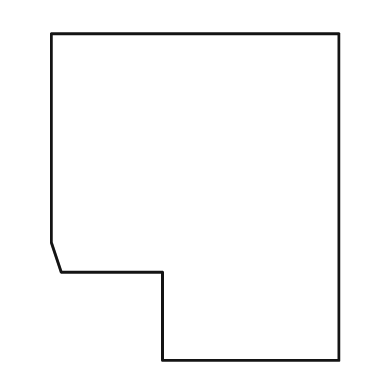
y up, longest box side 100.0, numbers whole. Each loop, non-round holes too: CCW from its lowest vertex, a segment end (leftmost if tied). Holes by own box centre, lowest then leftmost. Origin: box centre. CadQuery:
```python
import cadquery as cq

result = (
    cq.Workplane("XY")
    .moveTo(-10.0, -50.0)
    .lineTo(44.0, -50.0)
    .lineTo(44.0, 50.0)
    .lineTo(-44.0, 50.0)
    .lineTo(-44.0, -14.0)
    .lineTo(-41.0, -23.0)
    .lineTo(-10.0, -23.0)
    .close()
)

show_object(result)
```